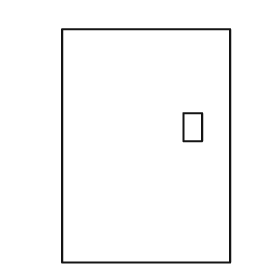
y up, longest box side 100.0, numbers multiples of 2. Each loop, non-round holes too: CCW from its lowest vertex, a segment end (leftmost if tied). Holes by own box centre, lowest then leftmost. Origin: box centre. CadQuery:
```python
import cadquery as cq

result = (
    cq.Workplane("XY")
    .moveTo(-36.0, -50.0)
    .lineTo(36.0, -50.0)
    .lineTo(36.0, 50.0)
    .lineTo(-36.0, 50.0)
    .close()
    .moveTo(16.0, 2.0)
    .lineTo(24.0, 2.0)
    .lineTo(24.0, 14.0)
    .lineTo(16.0, 14.0)
    .close()
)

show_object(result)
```